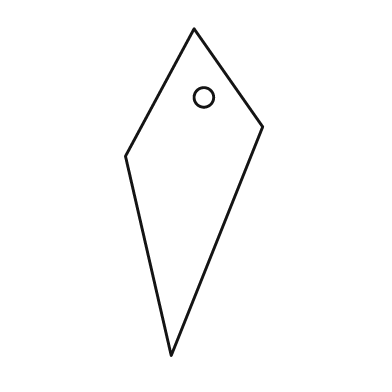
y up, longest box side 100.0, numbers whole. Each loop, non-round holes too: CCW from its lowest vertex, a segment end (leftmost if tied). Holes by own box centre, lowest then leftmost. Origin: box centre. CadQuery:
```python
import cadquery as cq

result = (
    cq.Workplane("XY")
    .moveTo(-7.0, -50.0)
    .lineTo(21.0, 20.0)
    .lineTo(0.0, 50.0)
    .lineTo(-21.0, 11.0)
    .close()
    .moveTo(3.0, 29.0)
    .circle(3.0)
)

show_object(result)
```